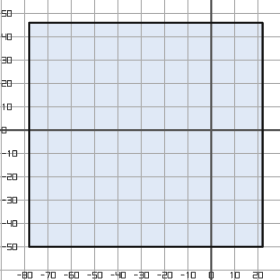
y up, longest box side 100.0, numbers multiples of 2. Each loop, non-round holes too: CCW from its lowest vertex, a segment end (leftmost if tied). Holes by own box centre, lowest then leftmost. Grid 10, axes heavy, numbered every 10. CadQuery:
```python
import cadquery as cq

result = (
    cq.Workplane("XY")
    .moveTo(-78.0, -50.0)
    .lineTo(22.0, -50.0)
    .lineTo(22.0, 46.0)
    .lineTo(-78.0, 46.0)
    .close()
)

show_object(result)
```